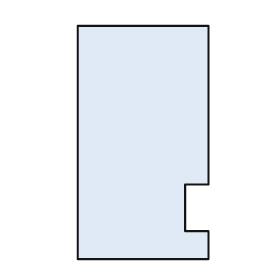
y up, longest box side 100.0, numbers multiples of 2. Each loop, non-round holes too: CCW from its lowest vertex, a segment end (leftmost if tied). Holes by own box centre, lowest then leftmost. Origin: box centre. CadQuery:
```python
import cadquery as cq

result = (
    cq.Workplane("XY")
    .moveTo(-28.0, -50.0)
    .lineTo(28.0, -50.0)
    .lineTo(28.0, -38.0)
    .lineTo(18.0, -38.0)
    .lineTo(18.0, -18.0)
    .lineTo(28.0, -18.0)
    .lineTo(28.0, 50.0)
    .lineTo(-28.0, 50.0)
    .close()
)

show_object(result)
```